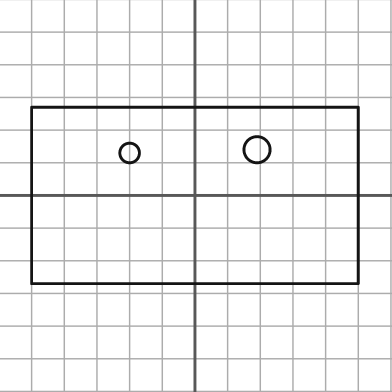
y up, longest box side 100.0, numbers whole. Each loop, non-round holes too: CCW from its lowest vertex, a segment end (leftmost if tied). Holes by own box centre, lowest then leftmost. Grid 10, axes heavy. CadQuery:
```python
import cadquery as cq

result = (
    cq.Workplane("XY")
    .moveTo(-50.0, -27.0)
    .lineTo(50.0, -27.0)
    .lineTo(50.0, 27.0)
    .lineTo(-50.0, 27.0)
    .close()
    .moveTo(-20.0, 13.0)
    .circle(3.0)
    .moveTo(19.0, 14.0)
    .circle(4.0)
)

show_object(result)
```